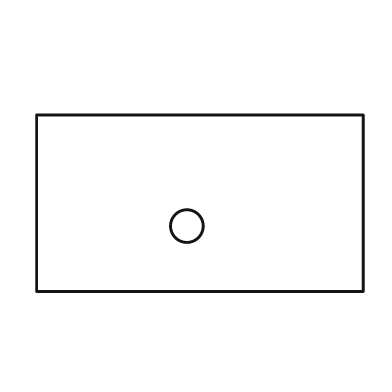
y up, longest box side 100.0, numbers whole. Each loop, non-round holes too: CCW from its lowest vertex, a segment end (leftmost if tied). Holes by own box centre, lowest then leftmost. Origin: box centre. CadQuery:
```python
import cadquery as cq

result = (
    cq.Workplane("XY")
    .moveTo(-50.0, -27.0)
    .lineTo(50.0, -27.0)
    .lineTo(50.0, 27.0)
    .lineTo(-50.0, 27.0)
    .close()
    .moveTo(-4.0, -7.0)
    .circle(5.0)
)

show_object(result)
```